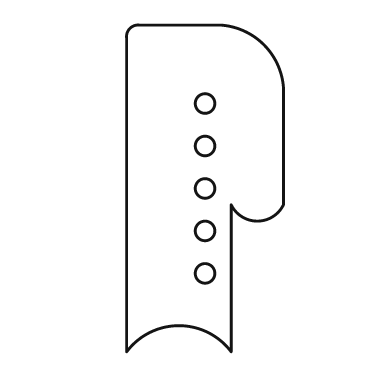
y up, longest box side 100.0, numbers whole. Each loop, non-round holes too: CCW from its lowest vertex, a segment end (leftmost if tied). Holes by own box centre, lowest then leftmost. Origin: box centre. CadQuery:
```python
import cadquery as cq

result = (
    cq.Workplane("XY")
    .moveTo(-24.0, -50.0)
    .threePointArc((-8.0, -42.0), (8.0, -50.0))
    .lineTo(8.0, -5.0)
    .threePointArc((16.0, -10.0), (24.0, -5.0))
    .lineTo(24.0, 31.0)
    .threePointArc((18.0, 44.0), (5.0, 50.0))
    .lineTo(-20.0, 50.0)
    .threePointArc((-23.0, 49.0), (-24.0, 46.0))
    .close()
    .moveTo(0.0, -26.0)
    .circle(3.0)
    .moveTo(0.0, -13.0)
    .circle(3.0)
    .moveTo(0.0, 0.0)
    .circle(3.0)
    .moveTo(0.0, 13.0)
    .circle(3.0)
    .moveTo(0.0, 26.0)
    .circle(3.0)
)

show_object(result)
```